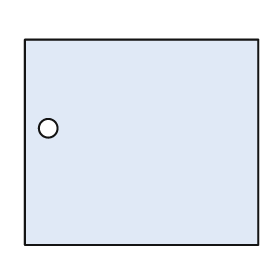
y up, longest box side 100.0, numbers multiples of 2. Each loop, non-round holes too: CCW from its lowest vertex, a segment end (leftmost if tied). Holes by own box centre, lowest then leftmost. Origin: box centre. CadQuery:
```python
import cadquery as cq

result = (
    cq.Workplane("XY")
    .moveTo(-50.0, -44.0)
    .lineTo(50.0, -44.0)
    .lineTo(50.0, 44.0)
    .lineTo(-50.0, 44.0)
    .close()
    .moveTo(-40.0, 6.0)
    .circle(4.0)
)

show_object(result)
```